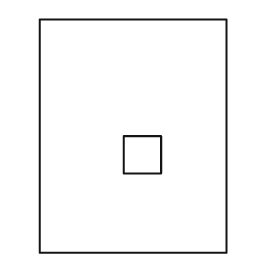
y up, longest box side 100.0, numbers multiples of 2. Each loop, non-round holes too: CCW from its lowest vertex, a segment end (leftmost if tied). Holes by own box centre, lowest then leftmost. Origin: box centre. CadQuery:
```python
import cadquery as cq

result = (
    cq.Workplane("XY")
    .moveTo(-40.0, -50.0)
    .lineTo(40.0, -50.0)
    .lineTo(40.0, 50.0)
    .lineTo(-40.0, 50.0)
    .close()
    .moveTo(-4.0, -16.0)
    .lineTo(12.0, -16.0)
    .lineTo(12.0, 0.0)
    .lineTo(-4.0, 0.0)
    .close()
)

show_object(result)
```